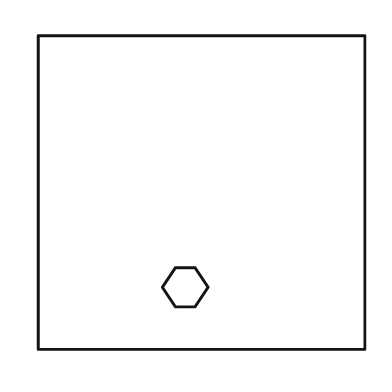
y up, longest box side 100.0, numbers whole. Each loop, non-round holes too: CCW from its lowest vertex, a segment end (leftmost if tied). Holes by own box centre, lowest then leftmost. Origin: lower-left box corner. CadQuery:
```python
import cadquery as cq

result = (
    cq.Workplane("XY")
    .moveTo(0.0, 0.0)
    .lineTo(100.0, 0.0)
    .lineTo(100.0, 96.0)
    .lineTo(0.0, 96.0)
    .close()
    .moveTo(42.0, 13.0)
    .lineTo(48.0, 13.0)
    .lineTo(52.0, 19.0)
    .lineTo(48.0, 25.0)
    .lineTo(42.0, 25.0)
    .lineTo(38.0, 19.0)
    .close()
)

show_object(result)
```